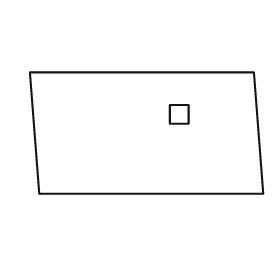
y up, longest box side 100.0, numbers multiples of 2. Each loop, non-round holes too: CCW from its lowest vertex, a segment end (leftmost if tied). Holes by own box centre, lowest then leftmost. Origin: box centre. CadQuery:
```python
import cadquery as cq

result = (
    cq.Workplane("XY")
    .moveTo(-46.0, -26.0)
    .lineTo(50.0, -26.0)
    .lineTo(46.0, 26.0)
    .lineTo(-50.0, 26.0)
    .close()
    .moveTo(10.0, 4.0)
    .lineTo(18.0, 4.0)
    .lineTo(18.0, 12.0)
    .lineTo(10.0, 12.0)
    .close()
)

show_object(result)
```